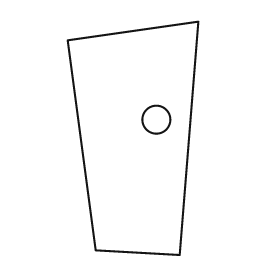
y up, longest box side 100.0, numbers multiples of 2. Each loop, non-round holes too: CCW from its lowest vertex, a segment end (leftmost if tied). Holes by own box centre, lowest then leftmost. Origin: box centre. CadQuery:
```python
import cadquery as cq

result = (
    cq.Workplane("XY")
    .moveTo(20.0, -50.0)
    .lineTo(28.0, 50.0)
    .lineTo(-28.0, 42.0)
    .lineTo(-16.0, -48.0)
    .close()
    .moveTo(10.0, 8.0)
    .circle(6.0)
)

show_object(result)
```